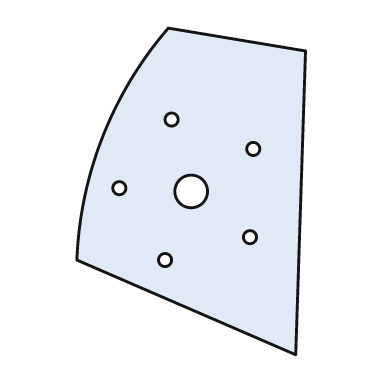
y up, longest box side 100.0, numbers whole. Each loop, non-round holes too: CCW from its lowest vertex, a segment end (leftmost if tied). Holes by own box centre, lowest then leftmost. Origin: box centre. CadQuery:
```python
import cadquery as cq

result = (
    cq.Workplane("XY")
    .moveTo(32.0, -50.0)
    .lineTo(35.0, 43.0)
    .lineTo(-7.0, 50.0)
    .threePointArc((-27.0, 17.0), (-35.0, -21.0))
    .close()
    .moveTo(-8.0, -21.0)
    .circle(2.0)
    .moveTo(18.0, -14.0)
    .circle(2.0)
    .moveTo(0.0, 0.0)
    .circle(5.0)
    .moveTo(-22.0, 1.0)
    .circle(2.0)
    .moveTo(19.0, 13.0)
    .circle(2.0)
    .moveTo(-6.0, 22.0)
    .circle(2.0)
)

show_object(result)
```